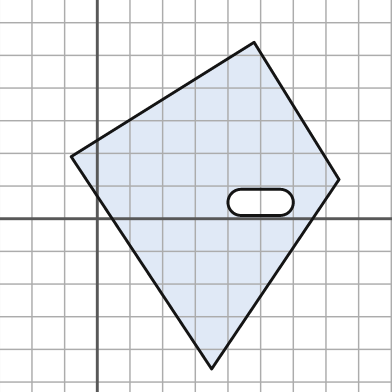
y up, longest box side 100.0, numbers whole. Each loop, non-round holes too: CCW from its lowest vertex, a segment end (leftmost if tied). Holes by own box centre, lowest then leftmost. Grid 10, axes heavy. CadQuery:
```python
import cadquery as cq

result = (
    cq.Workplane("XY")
    .moveTo(35.0, -46.0)
    .lineTo(74.0, 12.0)
    .lineTo(48.0, 54.0)
    .lineTo(-8.0, 19.0)
    .close()
    .moveTo(44.0, 1.0)
    .lineTo(56.0, 1.0)
    .threePointArc((60.0, 5.0), (56.0, 9.0))
    .lineTo(44.0, 9.0)
    .threePointArc((40.0, 5.0), (44.0, 1.0))
    .close()
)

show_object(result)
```